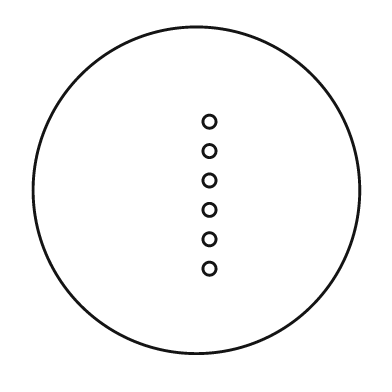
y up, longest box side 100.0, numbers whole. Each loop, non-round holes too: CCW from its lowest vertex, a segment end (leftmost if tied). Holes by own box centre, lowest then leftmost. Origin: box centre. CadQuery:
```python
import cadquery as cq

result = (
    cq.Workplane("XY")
    .moveTo(0.0, 0.0)
    .circle(50.0)
    .moveTo(4.0, -24.0)
    .circle(2.0)
    .moveTo(4.0, -15.0)
    .circle(2.0)
    .moveTo(4.0, -6.0)
    .circle(2.0)
    .moveTo(4.0, 3.0)
    .circle(2.0)
    .moveTo(4.0, 12.0)
    .circle(2.0)
    .moveTo(4.0, 21.0)
    .circle(2.0)
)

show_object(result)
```